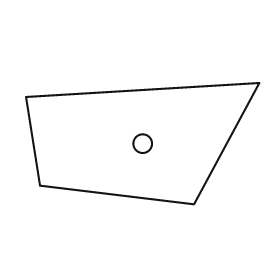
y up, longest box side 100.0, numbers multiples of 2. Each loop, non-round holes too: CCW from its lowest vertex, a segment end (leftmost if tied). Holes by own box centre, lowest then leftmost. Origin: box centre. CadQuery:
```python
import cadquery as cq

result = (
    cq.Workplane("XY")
    .moveTo(22.0, -26.0)
    .lineTo(50.0, 26.0)
    .lineTo(-50.0, 20.0)
    .lineTo(-44.0, -18.0)
    .close()
    .moveTo(0.0, 0.0)
    .circle(4.0)
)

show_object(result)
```